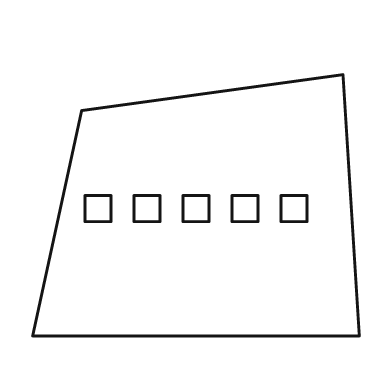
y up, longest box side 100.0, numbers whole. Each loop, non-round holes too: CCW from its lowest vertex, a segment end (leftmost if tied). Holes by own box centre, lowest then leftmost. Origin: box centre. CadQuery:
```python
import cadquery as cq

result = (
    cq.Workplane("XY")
    .moveTo(-50.0, -40.0)
    .lineTo(50.0, -40.0)
    .lineTo(45.0, 40.0)
    .lineTo(-35.0, 29.0)
    .close()
    .moveTo(-34.0, -5.0)
    .lineTo(-26.0, -5.0)
    .lineTo(-26.0, 3.0)
    .lineTo(-34.0, 3.0)
    .close()
    .moveTo(-19.0, -5.0)
    .lineTo(-11.0, -5.0)
    .lineTo(-11.0, 3.0)
    .lineTo(-19.0, 3.0)
    .close()
    .moveTo(-4.0, -5.0)
    .lineTo(4.0, -5.0)
    .lineTo(4.0, 3.0)
    .lineTo(-4.0, 3.0)
    .close()
    .moveTo(11.0, -5.0)
    .lineTo(19.0, -5.0)
    .lineTo(19.0, 3.0)
    .lineTo(11.0, 3.0)
    .close()
    .moveTo(26.0, -5.0)
    .lineTo(34.0, -5.0)
    .lineTo(34.0, 3.0)
    .lineTo(26.0, 3.0)
    .close()
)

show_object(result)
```